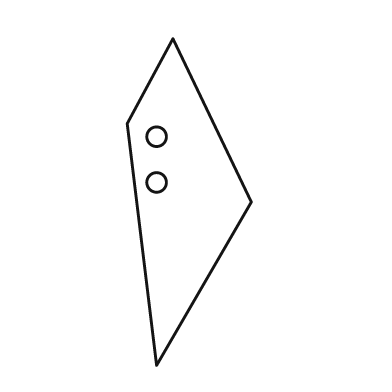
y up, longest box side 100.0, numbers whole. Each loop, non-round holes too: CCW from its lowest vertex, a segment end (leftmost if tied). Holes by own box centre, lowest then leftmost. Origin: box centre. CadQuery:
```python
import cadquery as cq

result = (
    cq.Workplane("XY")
    .moveTo(-10.0, -50.0)
    .lineTo(19.0, 0.0)
    .lineTo(-5.0, 50.0)
    .lineTo(-19.0, 24.0)
    .close()
    .moveTo(-10.0, 6.0)
    .circle(3.0)
    .moveTo(-10.0, 20.0)
    .circle(3.0)
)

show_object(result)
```